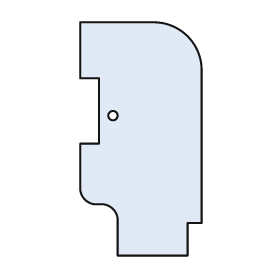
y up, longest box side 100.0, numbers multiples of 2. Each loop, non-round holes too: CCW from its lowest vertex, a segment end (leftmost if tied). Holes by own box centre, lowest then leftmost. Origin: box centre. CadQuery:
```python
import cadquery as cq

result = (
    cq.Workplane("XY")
    .moveTo(-10.0, -50.0)
    .lineTo(20.0, -50.0)
    .lineTo(20.0, -36.0)
    .lineTo(26.0, -36.0)
    .lineTo(26.0, 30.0)
    .threePointArc((20.0, 44.0), (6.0, 50.0))
    .lineTo(-26.0, 50.0)
    .lineTo(-26.0, 26.0)
    .lineTo(-18.0, 26.0)
    .lineTo(-18.0, -2.0)
    .lineTo(-26.0, -2.0)
    .lineTo(-26.0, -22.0)
    .threePointArc((-24.0, -26.0), (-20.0, -28.0))
    .lineTo(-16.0, -28.0)
    .threePointArc((-12.0, -30.0), (-10.0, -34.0))
    .close()
    .moveTo(-12.0, 10.0)
    .circle(2.0)
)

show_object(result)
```